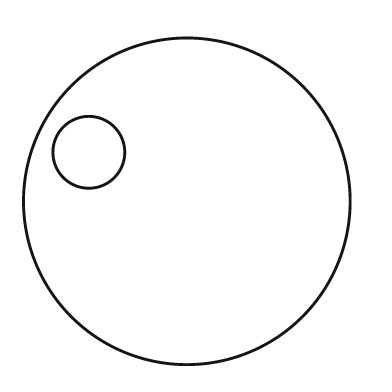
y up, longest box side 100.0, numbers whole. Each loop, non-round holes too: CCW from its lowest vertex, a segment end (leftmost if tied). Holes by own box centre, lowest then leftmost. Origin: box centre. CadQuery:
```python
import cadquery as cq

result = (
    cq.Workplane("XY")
    .moveTo(0.0, 0.0)
    .circle(50.0)
    .moveTo(-30.0, 15.0)
    .circle(11.0)
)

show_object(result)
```